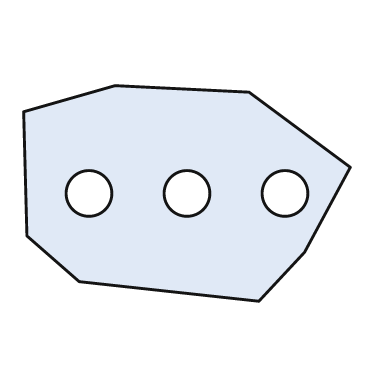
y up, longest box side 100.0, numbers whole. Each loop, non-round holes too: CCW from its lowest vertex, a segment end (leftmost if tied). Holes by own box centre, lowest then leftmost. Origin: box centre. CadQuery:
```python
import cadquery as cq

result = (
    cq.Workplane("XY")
    .moveTo(22.0, -33.0)
    .lineTo(36.0, -18.0)
    .lineTo(50.0, 8.0)
    .lineTo(19.0, 31.0)
    .lineTo(-22.0, 33.0)
    .lineTo(-50.0, 25.0)
    .lineTo(-49.0, -13.0)
    .lineTo(-33.0, -27.0)
    .close()
    .moveTo(-30.0, 0.0)
    .circle(7.0)
    .moveTo(0.0, 0.0)
    .circle(7.0)
    .moveTo(30.0, 0.0)
    .circle(7.0)
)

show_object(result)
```